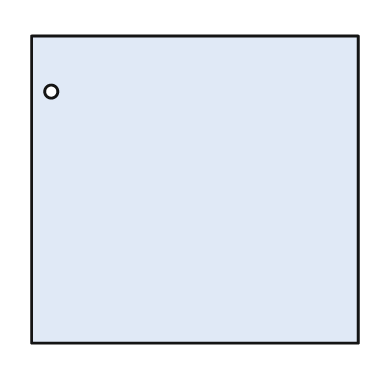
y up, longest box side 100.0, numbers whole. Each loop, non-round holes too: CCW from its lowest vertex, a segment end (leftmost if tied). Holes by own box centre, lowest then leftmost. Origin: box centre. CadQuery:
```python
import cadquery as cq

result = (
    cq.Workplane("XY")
    .moveTo(-50.0, -47.0)
    .lineTo(50.0, -47.0)
    .lineTo(50.0, 47.0)
    .lineTo(-50.0, 47.0)
    .close()
    .moveTo(-44.0, 30.0)
    .circle(2.0)
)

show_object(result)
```